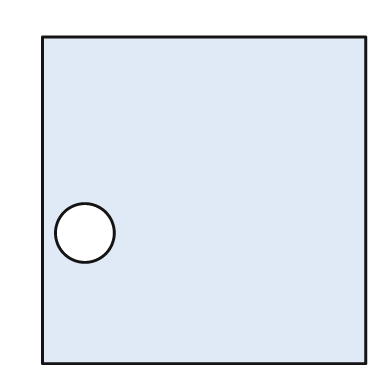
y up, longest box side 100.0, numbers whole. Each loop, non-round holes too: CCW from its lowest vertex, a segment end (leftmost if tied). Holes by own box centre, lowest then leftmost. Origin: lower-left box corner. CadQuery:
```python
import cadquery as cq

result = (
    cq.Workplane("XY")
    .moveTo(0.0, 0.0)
    .lineTo(99.0, 0.0)
    .lineTo(99.0, 100.0)
    .lineTo(0.0, 100.0)
    .close()
    .moveTo(13.0, 40.0)
    .circle(9.0)
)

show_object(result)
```